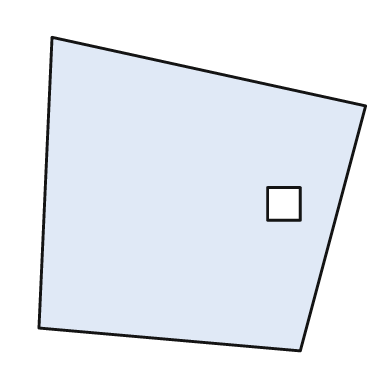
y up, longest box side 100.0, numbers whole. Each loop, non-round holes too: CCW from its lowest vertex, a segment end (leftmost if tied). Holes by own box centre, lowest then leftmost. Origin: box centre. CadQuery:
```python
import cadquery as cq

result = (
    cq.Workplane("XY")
    .moveTo(30.0, -48.0)
    .lineTo(50.0, 27.0)
    .lineTo(-46.0, 48.0)
    .lineTo(-50.0, -41.0)
    .close()
    .moveTo(20.0, -8.0)
    .lineTo(30.0, -8.0)
    .lineTo(30.0, 2.0)
    .lineTo(20.0, 2.0)
    .close()
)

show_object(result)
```